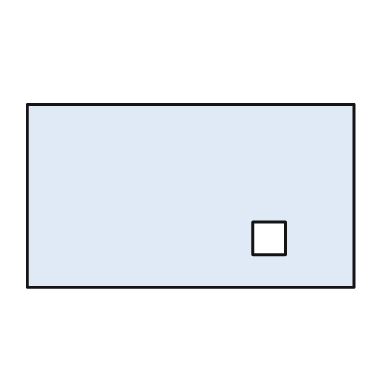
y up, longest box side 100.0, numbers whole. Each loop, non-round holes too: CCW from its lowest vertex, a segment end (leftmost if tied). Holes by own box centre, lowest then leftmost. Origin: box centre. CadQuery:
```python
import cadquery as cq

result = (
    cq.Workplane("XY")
    .moveTo(-50.0, -28.0)
    .lineTo(50.0, -28.0)
    .lineTo(50.0, 28.0)
    .lineTo(-50.0, 28.0)
    .close()
    .moveTo(19.0, -18.0)
    .lineTo(29.0, -18.0)
    .lineTo(29.0, -8.0)
    .lineTo(19.0, -8.0)
    .close()
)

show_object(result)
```